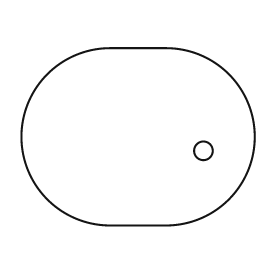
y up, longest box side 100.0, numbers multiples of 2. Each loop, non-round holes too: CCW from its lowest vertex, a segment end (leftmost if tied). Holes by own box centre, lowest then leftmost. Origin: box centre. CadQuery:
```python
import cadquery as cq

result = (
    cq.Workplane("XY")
    .moveTo(-12.0, -38.0)
    .lineTo(12.0, -38.0)
    .threePointArc((50.0, 0.0), (12.0, 38.0))
    .lineTo(-12.0, 38.0)
    .threePointArc((-50.0, 0.0), (-12.0, -38.0))
    .close()
    .moveTo(28.0, -6.0)
    .circle(4.0)
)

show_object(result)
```